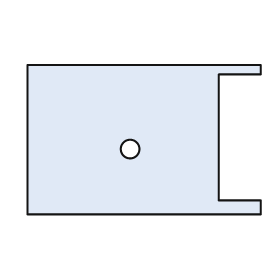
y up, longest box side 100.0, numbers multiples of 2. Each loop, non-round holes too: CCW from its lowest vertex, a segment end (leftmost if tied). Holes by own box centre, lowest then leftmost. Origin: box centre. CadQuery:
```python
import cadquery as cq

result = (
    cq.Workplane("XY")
    .moveTo(-50.0, -32.0)
    .lineTo(50.0, -32.0)
    .lineTo(50.0, -26.0)
    .lineTo(32.0, -26.0)
    .lineTo(32.0, 28.0)
    .lineTo(50.0, 28.0)
    .lineTo(50.0, 32.0)
    .lineTo(-50.0, 32.0)
    .close()
    .moveTo(-6.0, -4.0)
    .circle(4.0)
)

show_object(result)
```